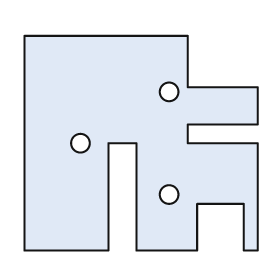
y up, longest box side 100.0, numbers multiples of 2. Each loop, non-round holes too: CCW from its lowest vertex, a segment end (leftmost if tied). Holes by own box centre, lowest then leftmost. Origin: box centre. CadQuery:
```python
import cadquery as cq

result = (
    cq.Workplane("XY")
    .moveTo(-50.0, -46.0)
    .lineTo(-14.0, -46.0)
    .lineTo(-14.0, 0.0)
    .lineTo(-2.0, 0.0)
    .lineTo(-2.0, -46.0)
    .lineTo(24.0, -46.0)
    .lineTo(24.0, -26.0)
    .lineTo(44.0, -26.0)
    .lineTo(44.0, -46.0)
    .lineTo(50.0, -46.0)
    .lineTo(50.0, 0.0)
    .lineTo(20.0, 0.0)
    .lineTo(20.0, 8.0)
    .lineTo(50.0, 8.0)
    .lineTo(50.0, 24.0)
    .lineTo(20.0, 24.0)
    .lineTo(20.0, 46.0)
    .lineTo(-50.0, 46.0)
    .close()
    .moveTo(12.0, -22.0)
    .circle(4.0)
    .moveTo(-26.0, 0.0)
    .circle(4.0)
    .moveTo(12.0, 22.0)
    .circle(4.0)
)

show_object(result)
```